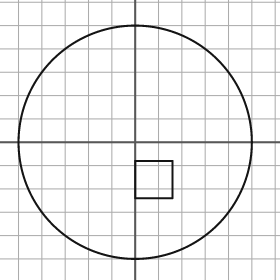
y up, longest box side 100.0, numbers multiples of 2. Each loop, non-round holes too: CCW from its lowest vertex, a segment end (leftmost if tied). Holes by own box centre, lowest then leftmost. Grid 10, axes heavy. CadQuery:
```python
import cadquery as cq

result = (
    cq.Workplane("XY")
    .moveTo(0.0, 0.0)
    .circle(50.0)
    .moveTo(0.0, -24.0)
    .lineTo(16.0, -24.0)
    .lineTo(16.0, -8.0)
    .lineTo(0.0, -8.0)
    .close()
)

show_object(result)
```